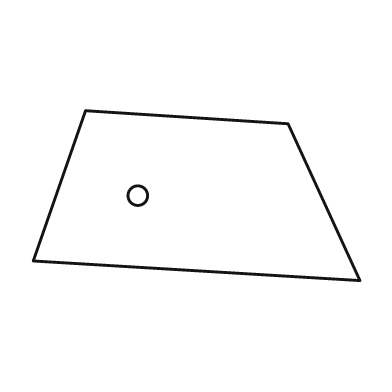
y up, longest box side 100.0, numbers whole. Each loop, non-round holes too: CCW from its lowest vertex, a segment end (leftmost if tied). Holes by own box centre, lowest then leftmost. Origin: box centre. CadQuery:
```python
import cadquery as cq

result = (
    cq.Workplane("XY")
    .moveTo(50.0, -26.0)
    .lineTo(28.0, 22.0)
    .lineTo(-34.0, 26.0)
    .lineTo(-50.0, -20.0)
    .close()
    .moveTo(-18.0, 0.0)
    .circle(3.0)
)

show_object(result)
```